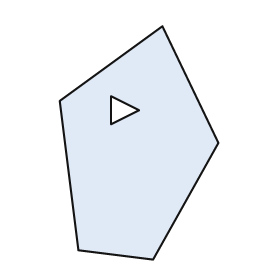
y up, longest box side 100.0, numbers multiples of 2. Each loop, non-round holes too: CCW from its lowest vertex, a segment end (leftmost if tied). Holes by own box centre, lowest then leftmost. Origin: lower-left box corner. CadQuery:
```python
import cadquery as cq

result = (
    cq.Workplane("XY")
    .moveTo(40.0, 0.0)
    .lineTo(68.0, 50.0)
    .lineTo(44.0, 100.0)
    .lineTo(0.0, 68.0)
    .lineTo(8.0, 4.0)
    .close()
    .moveTo(22.0, 58.0)
    .lineTo(34.0, 64.0)
    .lineTo(22.0, 70.0)
    .close()
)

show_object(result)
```